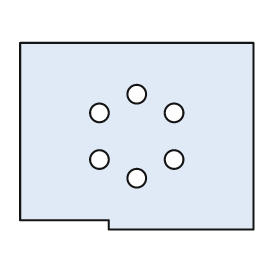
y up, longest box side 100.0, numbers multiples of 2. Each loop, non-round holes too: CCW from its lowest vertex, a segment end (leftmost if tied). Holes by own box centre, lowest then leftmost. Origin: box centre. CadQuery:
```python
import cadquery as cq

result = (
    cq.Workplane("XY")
    .moveTo(-12.0, -40.0)
    .lineTo(50.0, -40.0)
    .lineTo(50.0, 40.0)
    .lineTo(-50.0, 40.0)
    .lineTo(-50.0, -36.0)
    .lineTo(-12.0, -36.0)
    .close()
    .moveTo(0.0, -18.0)
    .circle(4.0)
    .moveTo(-16.0, -10.0)
    .circle(4.0)
    .moveTo(16.0, -10.0)
    .circle(4.0)
    .moveTo(-16.0, 10.0)
    .circle(4.0)
    .moveTo(16.0, 10.0)
    .circle(4.0)
    .moveTo(0.0, 18.0)
    .circle(4.0)
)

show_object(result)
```